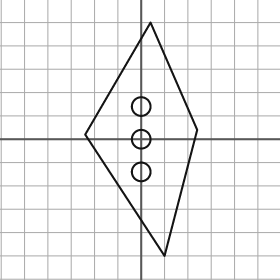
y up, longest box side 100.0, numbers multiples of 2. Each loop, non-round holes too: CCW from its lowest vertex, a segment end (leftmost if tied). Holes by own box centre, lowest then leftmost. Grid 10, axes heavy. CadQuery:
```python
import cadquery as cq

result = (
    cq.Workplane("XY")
    .moveTo(10.0, -50.0)
    .lineTo(24.0, 4.0)
    .lineTo(4.0, 50.0)
    .lineTo(-24.0, 2.0)
    .close()
    .moveTo(0.0, -14.0)
    .circle(4.0)
    .moveTo(0.0, 0.0)
    .circle(4.0)
    .moveTo(0.0, 14.0)
    .circle(4.0)
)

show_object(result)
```